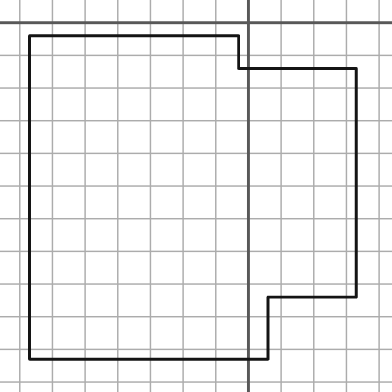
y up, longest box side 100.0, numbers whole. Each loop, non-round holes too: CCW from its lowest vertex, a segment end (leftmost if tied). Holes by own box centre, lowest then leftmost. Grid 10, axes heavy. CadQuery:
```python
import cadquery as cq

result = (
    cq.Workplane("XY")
    .moveTo(-67.0, -103.0)
    .lineTo(6.0, -103.0)
    .lineTo(6.0, -84.0)
    .lineTo(33.0, -84.0)
    .lineTo(33.0, -14.0)
    .lineTo(-3.0, -14.0)
    .lineTo(-3.0, -4.0)
    .lineTo(-67.0, -4.0)
    .close()
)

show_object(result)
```